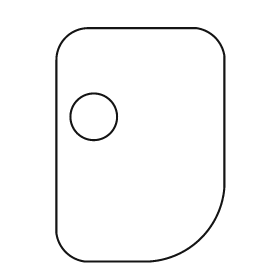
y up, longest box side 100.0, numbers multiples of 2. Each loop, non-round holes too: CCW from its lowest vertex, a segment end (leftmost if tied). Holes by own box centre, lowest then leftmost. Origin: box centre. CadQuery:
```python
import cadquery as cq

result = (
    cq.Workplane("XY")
    .moveTo(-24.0, -50.0)
    .lineTo(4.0, -50.0)
    .threePointArc((26.0, -40.0), (36.0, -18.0))
    .lineTo(36.0, 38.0)
    .threePointArc((32.0, 46.0), (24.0, 50.0))
    .lineTo(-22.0, 50.0)
    .threePointArc((-32.0, 46.0), (-36.0, 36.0))
    .lineTo(-36.0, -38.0)
    .threePointArc((-32.0, -46.0), (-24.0, -50.0))
    .close()
    .moveTo(-20.0, 12.0)
    .circle(10.0)
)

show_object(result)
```